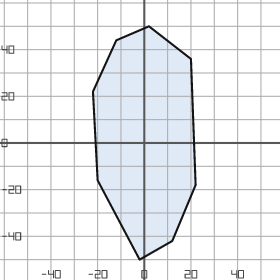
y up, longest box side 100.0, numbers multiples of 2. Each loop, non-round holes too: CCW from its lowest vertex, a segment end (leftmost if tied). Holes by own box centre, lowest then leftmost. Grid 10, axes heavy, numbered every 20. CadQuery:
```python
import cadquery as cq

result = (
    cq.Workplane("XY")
    .moveTo(-2.0, -50.0)
    .lineTo(12.0, -42.0)
    .lineTo(22.0, -18.0)
    .lineTo(20.0, 36.0)
    .lineTo(2.0, 50.0)
    .lineTo(-12.0, 44.0)
    .lineTo(-22.0, 22.0)
    .lineTo(-20.0, -16.0)
    .close()
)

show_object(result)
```